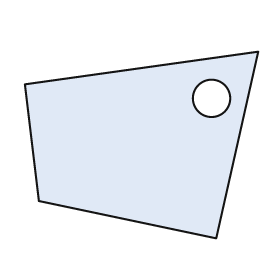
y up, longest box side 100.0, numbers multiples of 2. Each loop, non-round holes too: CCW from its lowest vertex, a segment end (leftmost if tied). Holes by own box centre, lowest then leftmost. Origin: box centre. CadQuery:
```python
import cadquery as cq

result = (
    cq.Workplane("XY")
    .moveTo(32.0, -40.0)
    .lineTo(50.0, 40.0)
    .lineTo(-50.0, 26.0)
    .lineTo(-44.0, -24.0)
    .close()
    .moveTo(30.0, 20.0)
    .circle(8.0)
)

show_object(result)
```